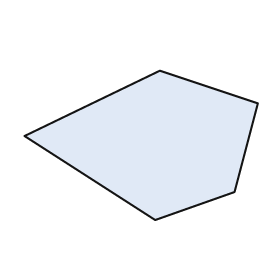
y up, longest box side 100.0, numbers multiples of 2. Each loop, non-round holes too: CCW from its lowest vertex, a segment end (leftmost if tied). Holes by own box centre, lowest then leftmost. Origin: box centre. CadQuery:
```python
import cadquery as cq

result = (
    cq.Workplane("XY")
    .moveTo(6.0, -32.0)
    .lineTo(40.0, -20.0)
    .lineTo(50.0, 18.0)
    .lineTo(8.0, 32.0)
    .lineTo(-50.0, 4.0)
    .close()
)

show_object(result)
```